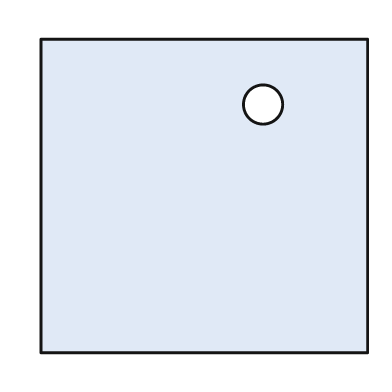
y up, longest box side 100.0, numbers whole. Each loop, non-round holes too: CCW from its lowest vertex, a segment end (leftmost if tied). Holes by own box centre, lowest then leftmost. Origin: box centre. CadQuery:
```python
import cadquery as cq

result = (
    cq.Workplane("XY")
    .moveTo(-50.0, -48.0)
    .lineTo(50.0, -48.0)
    .lineTo(50.0, 48.0)
    .lineTo(-50.0, 48.0)
    .close()
    .moveTo(18.0, 28.0)
    .circle(6.0)
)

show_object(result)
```